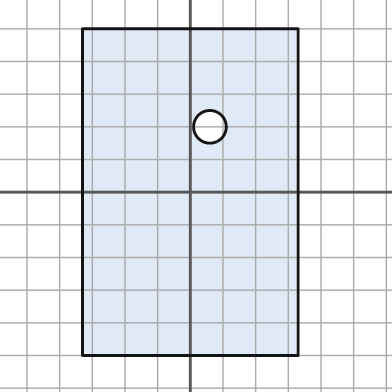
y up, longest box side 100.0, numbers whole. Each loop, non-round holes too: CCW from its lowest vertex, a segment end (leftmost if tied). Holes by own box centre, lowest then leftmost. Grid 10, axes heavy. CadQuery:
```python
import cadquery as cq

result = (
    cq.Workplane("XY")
    .moveTo(-33.0, -50.0)
    .lineTo(33.0, -50.0)
    .lineTo(33.0, 50.0)
    .lineTo(-33.0, 50.0)
    .close()
    .moveTo(6.0, 20.0)
    .circle(5.0)
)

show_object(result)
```